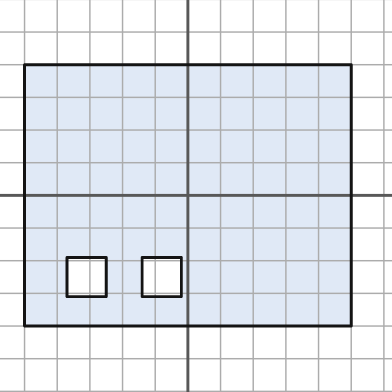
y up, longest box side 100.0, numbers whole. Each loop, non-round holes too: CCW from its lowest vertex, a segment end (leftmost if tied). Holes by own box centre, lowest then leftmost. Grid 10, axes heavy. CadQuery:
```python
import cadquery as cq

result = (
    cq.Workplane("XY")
    .moveTo(-50.0, -40.0)
    .lineTo(50.0, -40.0)
    .lineTo(50.0, 40.0)
    .lineTo(-50.0, 40.0)
    .close()
    .moveTo(-37.0, -31.0)
    .lineTo(-25.0, -31.0)
    .lineTo(-25.0, -19.0)
    .lineTo(-37.0, -19.0)
    .close()
    .moveTo(-14.0, -31.0)
    .lineTo(-2.0, -31.0)
    .lineTo(-2.0, -19.0)
    .lineTo(-14.0, -19.0)
    .close()
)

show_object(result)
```